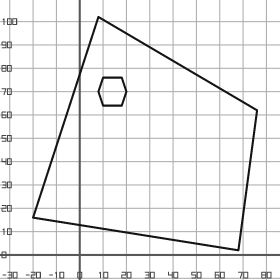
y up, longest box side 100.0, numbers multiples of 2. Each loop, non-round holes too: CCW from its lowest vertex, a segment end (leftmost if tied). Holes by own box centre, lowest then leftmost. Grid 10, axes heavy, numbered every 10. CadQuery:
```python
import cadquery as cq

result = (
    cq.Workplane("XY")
    .moveTo(68.0, 2.0)
    .lineTo(76.0, 62.0)
    .lineTo(8.0, 102.0)
    .lineTo(-20.0, 16.0)
    .close()
    .moveTo(10.0, 64.0)
    .lineTo(18.0, 64.0)
    .lineTo(20.0, 70.0)
    .lineTo(18.0, 76.0)
    .lineTo(10.0, 76.0)
    .lineTo(8.0, 70.0)
    .close()
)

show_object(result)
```